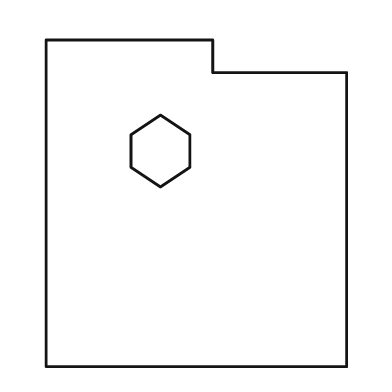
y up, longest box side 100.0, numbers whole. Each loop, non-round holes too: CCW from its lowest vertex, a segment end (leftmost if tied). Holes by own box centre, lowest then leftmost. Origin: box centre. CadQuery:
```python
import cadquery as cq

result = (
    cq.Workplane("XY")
    .moveTo(-46.0, -50.0)
    .lineTo(46.0, -50.0)
    .lineTo(46.0, 40.0)
    .lineTo(5.0, 40.0)
    .lineTo(5.0, 50.0)
    .lineTo(-46.0, 50.0)
    .close()
    .moveTo(-11.0, 5.0)
    .lineTo(-2.0, 11.0)
    .lineTo(-2.0, 21.0)
    .lineTo(-11.0, 27.0)
    .lineTo(-20.0, 21.0)
    .lineTo(-20.0, 11.0)
    .close()
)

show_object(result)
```